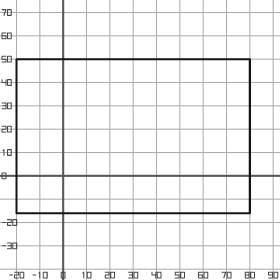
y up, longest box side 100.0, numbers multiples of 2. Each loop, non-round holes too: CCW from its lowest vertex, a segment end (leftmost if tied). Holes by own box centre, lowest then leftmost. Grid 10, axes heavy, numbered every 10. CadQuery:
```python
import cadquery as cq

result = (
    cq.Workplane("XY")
    .moveTo(-20.0, -16.0)
    .lineTo(80.0, -16.0)
    .lineTo(80.0, 50.0)
    .lineTo(-20.0, 50.0)
    .close()
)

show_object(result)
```